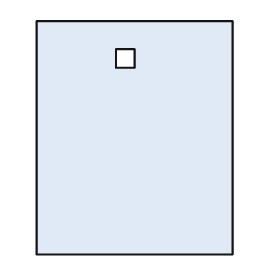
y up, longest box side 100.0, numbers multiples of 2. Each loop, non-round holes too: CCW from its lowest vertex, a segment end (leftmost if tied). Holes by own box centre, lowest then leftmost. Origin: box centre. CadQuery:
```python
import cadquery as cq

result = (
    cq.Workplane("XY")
    .moveTo(-42.0, -50.0)
    .lineTo(42.0, -50.0)
    .lineTo(42.0, 50.0)
    .lineTo(-42.0, 50.0)
    .close()
    .moveTo(-8.0, 30.0)
    .lineTo(0.0, 30.0)
    .lineTo(0.0, 38.0)
    .lineTo(-8.0, 38.0)
    .close()
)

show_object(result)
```